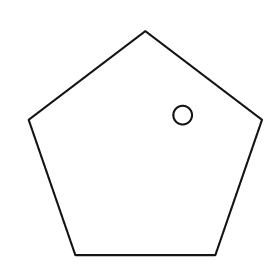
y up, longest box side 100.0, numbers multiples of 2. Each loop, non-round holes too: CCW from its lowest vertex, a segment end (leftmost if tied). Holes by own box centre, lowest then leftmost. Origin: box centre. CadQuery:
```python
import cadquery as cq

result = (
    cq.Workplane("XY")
    .moveTo(-30.0, -48.0)
    .lineTo(30.0, -48.0)
    .lineTo(50.0, 10.0)
    .lineTo(0.0, 48.0)
    .lineTo(-50.0, 10.0)
    .close()
    .moveTo(16.0, 12.0)
    .circle(4.0)
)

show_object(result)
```